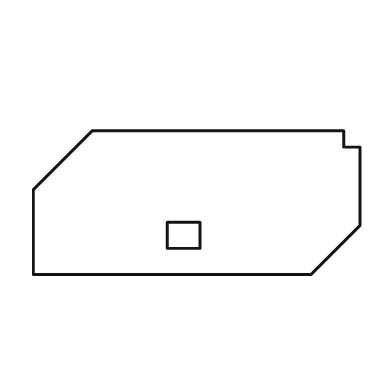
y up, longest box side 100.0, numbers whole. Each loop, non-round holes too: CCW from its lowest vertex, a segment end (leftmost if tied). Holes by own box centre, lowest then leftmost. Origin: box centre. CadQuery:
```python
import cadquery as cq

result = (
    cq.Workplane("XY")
    .moveTo(-50.0, -22.0)
    .lineTo(35.0, -22.0)
    .lineTo(50.0, -7.0)
    .lineTo(50.0, 17.0)
    .lineTo(45.0, 17.0)
    .lineTo(45.0, 22.0)
    .lineTo(-32.0, 22.0)
    .lineTo(-50.0, 4.0)
    .close()
    .moveTo(-9.0, -14.0)
    .lineTo(1.0, -14.0)
    .lineTo(1.0, -6.0)
    .lineTo(-9.0, -6.0)
    .close()
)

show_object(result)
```